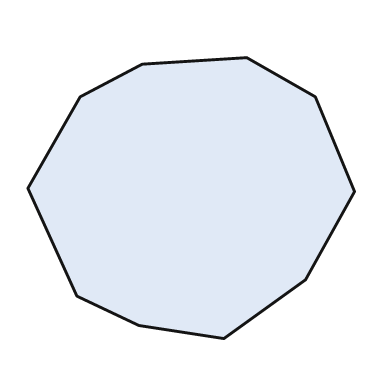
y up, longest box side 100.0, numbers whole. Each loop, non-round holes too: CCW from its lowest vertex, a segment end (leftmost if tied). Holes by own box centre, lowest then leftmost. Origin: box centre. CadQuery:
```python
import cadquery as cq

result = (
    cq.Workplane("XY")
    .moveTo(10.0, -43.0)
    .lineTo(35.0, -25.0)
    .lineTo(50.0, 2.0)
    .lineTo(38.0, 31.0)
    .lineTo(17.0, 43.0)
    .lineTo(-15.0, 41.0)
    .lineTo(-34.0, 31.0)
    .lineTo(-50.0, 3.0)
    .lineTo(-35.0, -30.0)
    .lineTo(-16.0, -39.0)
    .close()
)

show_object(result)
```